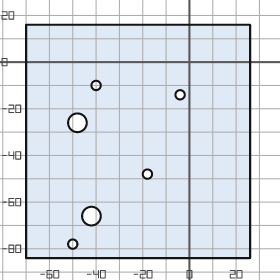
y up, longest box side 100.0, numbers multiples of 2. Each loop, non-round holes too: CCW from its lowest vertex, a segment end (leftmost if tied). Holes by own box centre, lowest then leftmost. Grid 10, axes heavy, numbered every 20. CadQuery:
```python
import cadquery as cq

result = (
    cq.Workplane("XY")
    .moveTo(-70.0, -84.0)
    .lineTo(26.0, -84.0)
    .lineTo(26.0, 16.0)
    .lineTo(-70.0, 16.0)
    .close()
    .moveTo(-50.0, -78.0)
    .circle(2.0)
    .moveTo(-42.0, -66.0)
    .circle(4.0)
    .moveTo(-18.0, -48.0)
    .circle(2.0)
    .moveTo(-48.0, -26.0)
    .circle(4.0)
    .moveTo(-4.0, -14.0)
    .circle(2.0)
    .moveTo(-40.0, -10.0)
    .circle(2.0)
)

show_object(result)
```